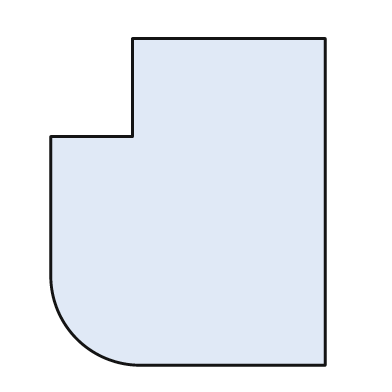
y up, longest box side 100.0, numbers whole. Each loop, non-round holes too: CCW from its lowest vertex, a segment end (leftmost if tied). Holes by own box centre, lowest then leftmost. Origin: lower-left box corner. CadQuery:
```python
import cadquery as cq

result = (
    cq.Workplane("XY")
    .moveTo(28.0, 0.0)
    .lineTo(84.0, 0.0)
    .lineTo(84.0, 100.0)
    .lineTo(25.0, 100.0)
    .lineTo(25.0, 70.0)
    .lineTo(0.0, 70.0)
    .lineTo(0.0, 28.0)
    .threePointArc((8.0, 8.0), (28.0, 0.0))
    .close()
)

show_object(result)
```